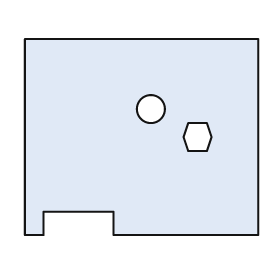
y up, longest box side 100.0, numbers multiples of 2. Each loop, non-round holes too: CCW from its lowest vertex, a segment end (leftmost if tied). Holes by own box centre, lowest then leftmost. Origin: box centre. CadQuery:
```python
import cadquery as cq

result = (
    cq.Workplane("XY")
    .moveTo(-50.0, -42.0)
    .lineTo(-42.0, -42.0)
    .lineTo(-42.0, -32.0)
    .lineTo(-12.0, -32.0)
    .lineTo(-12.0, -42.0)
    .lineTo(50.0, -42.0)
    .lineTo(50.0, 42.0)
    .lineTo(-50.0, 42.0)
    .close()
    .moveTo(20.0, -6.0)
    .lineTo(28.0, -6.0)
    .lineTo(30.0, 0.0)
    .lineTo(28.0, 6.0)
    .lineTo(20.0, 6.0)
    .lineTo(18.0, 0.0)
    .close()
    .moveTo(4.0, 12.0)
    .circle(6.0)
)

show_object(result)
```